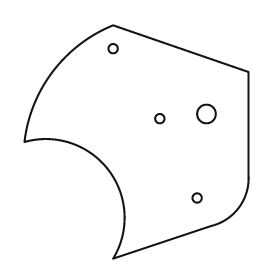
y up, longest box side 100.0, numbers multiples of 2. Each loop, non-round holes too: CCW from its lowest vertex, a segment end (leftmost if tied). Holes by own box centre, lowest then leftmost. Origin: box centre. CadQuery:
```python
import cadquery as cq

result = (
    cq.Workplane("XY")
    .moveTo(-10.0, -50.0)
    .lineTo(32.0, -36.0)
    .threePointArc((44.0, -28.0), (48.0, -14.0))
    .lineTo(48.0, 30.0)
    .lineTo(-10.0, 50.0)
    .threePointArc((-36.0, 30.0), (-48.0, 0.0))
    .threePointArc((-12.0, -12.0), (-10.0, -50.0))
    .close()
    .moveTo(26.0, -24.0)
    .circle(2.0)
    .moveTo(10.0, 10.0)
    .circle(2.0)
    .moveTo(30.0, 12.0)
    .circle(4.0)
    .moveTo(-10.0, 40.0)
    .circle(2.0)
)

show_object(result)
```